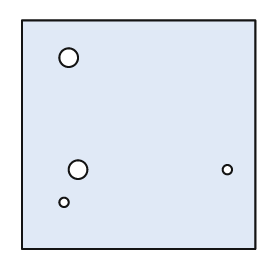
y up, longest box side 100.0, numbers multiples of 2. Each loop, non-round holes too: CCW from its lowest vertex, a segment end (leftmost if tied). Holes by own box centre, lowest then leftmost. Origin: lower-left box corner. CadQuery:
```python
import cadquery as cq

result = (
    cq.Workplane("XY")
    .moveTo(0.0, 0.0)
    .lineTo(100.0, 0.0)
    .lineTo(100.0, 98.0)
    .lineTo(0.0, 98.0)
    .close()
    .moveTo(18.0, 20.0)
    .circle(2.0)
    .moveTo(24.0, 34.0)
    .circle(4.0)
    .moveTo(88.0, 34.0)
    .circle(2.0)
    .moveTo(20.0, 82.0)
    .circle(4.0)
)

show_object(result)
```